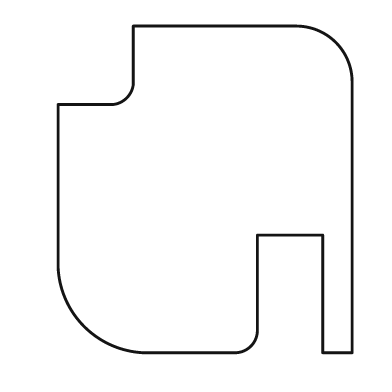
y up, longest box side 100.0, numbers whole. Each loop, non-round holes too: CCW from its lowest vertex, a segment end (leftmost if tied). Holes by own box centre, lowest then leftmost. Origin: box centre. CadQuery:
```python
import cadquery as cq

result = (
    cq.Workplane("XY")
    .moveTo(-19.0, -50.0)
    .lineTo(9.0, -50.0)
    .threePointArc((14.0, -48.0), (16.0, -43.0))
    .lineTo(16.0, -14.0)
    .lineTo(36.0, -14.0)
    .lineTo(36.0, -50.0)
    .lineTo(45.0, -50.0)
    .lineTo(45.0, 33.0)
    .threePointArc((40.0, 45.0), (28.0, 50.0))
    .lineTo(-22.0, 50.0)
    .lineTo(-22.0, 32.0)
    .threePointArc((-24.0, 28.0), (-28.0, 26.0))
    .lineTo(-45.0, 26.0)
    .lineTo(-45.0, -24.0)
    .threePointArc((-37.0, -42.0), (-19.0, -50.0))
    .close()
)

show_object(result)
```